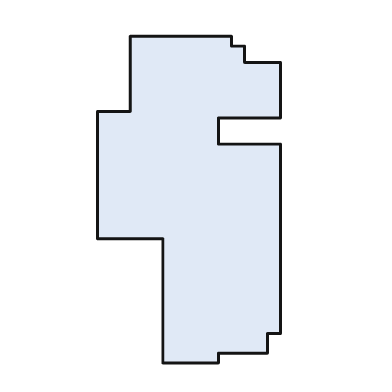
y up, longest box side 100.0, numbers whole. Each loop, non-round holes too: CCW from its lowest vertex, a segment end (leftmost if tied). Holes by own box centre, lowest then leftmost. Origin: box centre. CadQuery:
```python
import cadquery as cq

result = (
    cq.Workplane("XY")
    .moveTo(-8.0, -50.0)
    .lineTo(9.0, -50.0)
    .lineTo(9.0, -47.0)
    .lineTo(24.0, -47.0)
    .lineTo(24.0, -41.0)
    .lineTo(28.0, -41.0)
    .lineTo(28.0, 17.0)
    .lineTo(9.0, 17.0)
    .lineTo(9.0, 25.0)
    .lineTo(28.0, 25.0)
    .lineTo(28.0, 42.0)
    .lineTo(17.0, 42.0)
    .lineTo(17.0, 47.0)
    .lineTo(13.0, 47.0)
    .lineTo(13.0, 50.0)
    .lineTo(-18.0, 50.0)
    .lineTo(-18.0, 27.0)
    .lineTo(-28.0, 27.0)
    .lineTo(-28.0, -12.0)
    .lineTo(-8.0, -12.0)
    .close()
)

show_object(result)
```